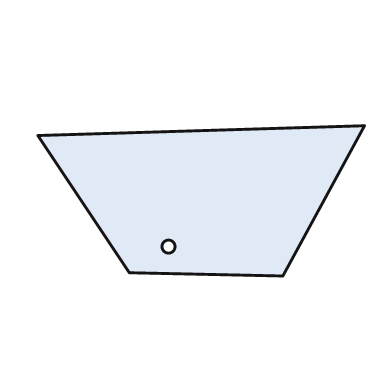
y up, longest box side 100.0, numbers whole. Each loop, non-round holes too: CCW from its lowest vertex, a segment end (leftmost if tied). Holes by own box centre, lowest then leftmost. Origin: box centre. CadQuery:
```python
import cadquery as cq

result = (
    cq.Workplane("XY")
    .moveTo(25.0, -23.0)
    .lineTo(50.0, 23.0)
    .lineTo(-50.0, 20.0)
    .lineTo(-22.0, -22.0)
    .close()
    .moveTo(-10.0, -14.0)
    .circle(2.0)
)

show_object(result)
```